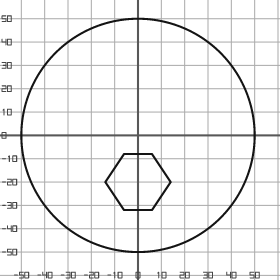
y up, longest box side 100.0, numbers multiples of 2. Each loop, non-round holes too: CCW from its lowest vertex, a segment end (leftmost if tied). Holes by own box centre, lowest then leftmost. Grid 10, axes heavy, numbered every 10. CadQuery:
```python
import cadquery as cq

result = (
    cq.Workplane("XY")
    .moveTo(0.0, 0.0)
    .circle(50.0)
    .moveTo(-6.0, -32.0)
    .lineTo(6.0, -32.0)
    .lineTo(14.0, -20.0)
    .lineTo(6.0, -8.0)
    .lineTo(-6.0, -8.0)
    .lineTo(-14.0, -20.0)
    .close()
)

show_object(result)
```